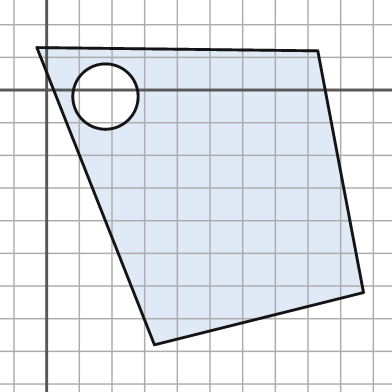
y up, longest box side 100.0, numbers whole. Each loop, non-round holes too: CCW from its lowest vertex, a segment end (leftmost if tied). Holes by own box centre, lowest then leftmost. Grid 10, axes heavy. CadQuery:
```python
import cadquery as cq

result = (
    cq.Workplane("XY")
    .moveTo(33.0, -78.0)
    .lineTo(97.0, -62.0)
    .lineTo(83.0, 12.0)
    .lineTo(-3.0, 13.0)
    .close()
    .moveTo(18.0, -2.0)
    .circle(10.0)
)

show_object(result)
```